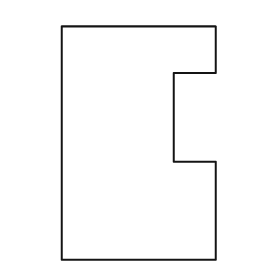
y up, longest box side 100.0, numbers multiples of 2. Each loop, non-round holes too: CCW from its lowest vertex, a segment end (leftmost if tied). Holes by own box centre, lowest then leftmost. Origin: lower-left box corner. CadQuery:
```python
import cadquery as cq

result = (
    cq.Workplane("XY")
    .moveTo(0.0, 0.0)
    .lineTo(66.0, 0.0)
    .lineTo(66.0, 42.0)
    .lineTo(48.0, 42.0)
    .lineTo(48.0, 80.0)
    .lineTo(66.0, 80.0)
    .lineTo(66.0, 100.0)
    .lineTo(0.0, 100.0)
    .close()
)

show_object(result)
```